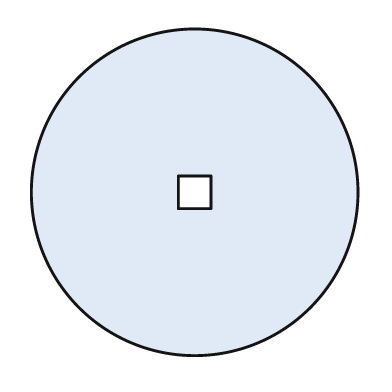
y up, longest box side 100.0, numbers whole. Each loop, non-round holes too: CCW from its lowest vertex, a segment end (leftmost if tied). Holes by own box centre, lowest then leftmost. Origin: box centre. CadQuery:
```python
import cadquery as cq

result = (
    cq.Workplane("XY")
    .moveTo(0.0, 0.0)
    .circle(50.0)
    .moveTo(-5.0, -5.0)
    .lineTo(5.0, -5.0)
    .lineTo(5.0, 5.0)
    .lineTo(-5.0, 5.0)
    .close()
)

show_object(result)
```